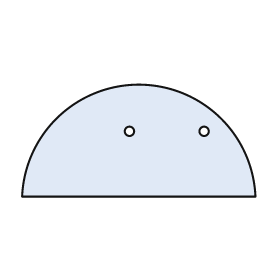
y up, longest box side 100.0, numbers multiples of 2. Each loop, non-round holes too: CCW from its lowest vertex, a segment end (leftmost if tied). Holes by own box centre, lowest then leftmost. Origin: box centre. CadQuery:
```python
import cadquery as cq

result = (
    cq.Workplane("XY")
    .moveTo(-50.0, -24.0)
    .lineTo(50.0, -24.0)
    .threePointArc((0.0, 24.0), (-50.0, -24.0))
    .close()
    .moveTo(-4.0, 4.0)
    .circle(2.0)
    .moveTo(28.0, 4.0)
    .circle(2.0)
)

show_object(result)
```